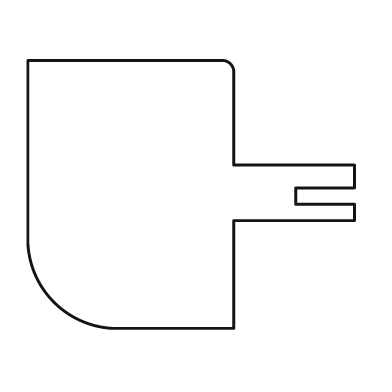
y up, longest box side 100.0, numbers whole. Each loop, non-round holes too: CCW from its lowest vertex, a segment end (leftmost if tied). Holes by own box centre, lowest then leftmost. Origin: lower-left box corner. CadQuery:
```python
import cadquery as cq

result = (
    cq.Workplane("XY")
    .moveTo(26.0, 0.0)
    .lineTo(63.0, 0.0)
    .lineTo(63.0, 33.0)
    .lineTo(100.0, 33.0)
    .lineTo(100.0, 38.0)
    .lineTo(82.0, 38.0)
    .lineTo(82.0, 43.0)
    .lineTo(100.0, 43.0)
    .lineTo(100.0, 50.0)
    .lineTo(63.0, 50.0)
    .lineTo(63.0, 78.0)
    .threePointArc((62.0, 81.0), (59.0, 82.0))
    .lineTo(0.0, 82.0)
    .lineTo(0.0, 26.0)
    .threePointArc((8.0, 8.0), (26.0, 0.0))
    .close()
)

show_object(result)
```